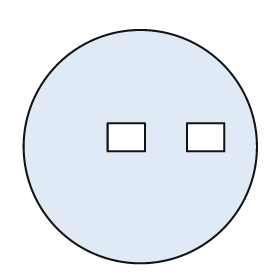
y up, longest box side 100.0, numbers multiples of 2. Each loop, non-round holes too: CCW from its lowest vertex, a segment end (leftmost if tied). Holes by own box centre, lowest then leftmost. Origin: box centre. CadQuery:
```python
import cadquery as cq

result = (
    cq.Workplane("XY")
    .moveTo(0.0, 0.0)
    .circle(50.0)
    .moveTo(-14.0, -2.0)
    .lineTo(2.0, -2.0)
    .lineTo(2.0, 10.0)
    .lineTo(-14.0, 10.0)
    .close()
    .moveTo(20.0, -2.0)
    .lineTo(36.0, -2.0)
    .lineTo(36.0, 10.0)
    .lineTo(20.0, 10.0)
    .close()
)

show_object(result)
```